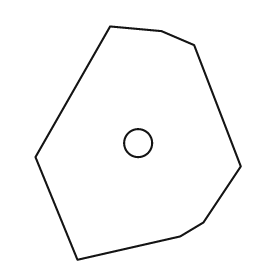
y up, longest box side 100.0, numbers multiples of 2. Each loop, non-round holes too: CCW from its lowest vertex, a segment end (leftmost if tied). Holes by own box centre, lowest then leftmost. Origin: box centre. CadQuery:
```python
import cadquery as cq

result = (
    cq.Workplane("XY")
    .moveTo(-26.0, -50.0)
    .lineTo(18.0, -40.0)
    .lineTo(28.0, -34.0)
    .lineTo(44.0, -10.0)
    .lineTo(24.0, 42.0)
    .lineTo(10.0, 48.0)
    .lineTo(-12.0, 50.0)
    .lineTo(-44.0, -6.0)
    .close()
    .moveTo(0.0, 0.0)
    .circle(6.0)
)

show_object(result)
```